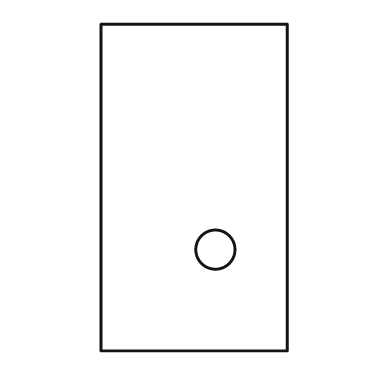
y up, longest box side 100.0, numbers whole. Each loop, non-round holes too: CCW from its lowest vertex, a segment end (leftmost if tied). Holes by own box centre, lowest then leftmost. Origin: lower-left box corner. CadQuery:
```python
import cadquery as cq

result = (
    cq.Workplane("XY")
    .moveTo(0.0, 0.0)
    .lineTo(57.0, 0.0)
    .lineTo(57.0, 100.0)
    .lineTo(0.0, 100.0)
    .close()
    .moveTo(35.0, 31.0)
    .circle(6.0)
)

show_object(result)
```